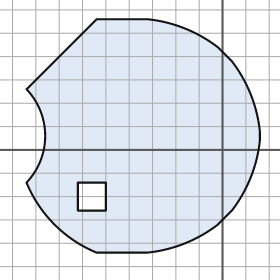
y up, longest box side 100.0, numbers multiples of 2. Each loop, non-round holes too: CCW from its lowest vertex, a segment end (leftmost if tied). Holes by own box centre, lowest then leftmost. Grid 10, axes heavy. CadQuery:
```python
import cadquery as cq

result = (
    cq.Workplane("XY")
    .moveTo(-54.0, -44.0)
    .lineTo(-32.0, -44.0)
    .threePointArc((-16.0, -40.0), (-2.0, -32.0))
    .lineTo(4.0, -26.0)
    .threePointArc((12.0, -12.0), (16.0, 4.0))
    .lineTo(16.0, 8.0)
    .threePointArc((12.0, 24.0), (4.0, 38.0))
    .lineTo(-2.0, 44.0)
    .threePointArc((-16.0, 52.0), (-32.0, 56.0))
    .lineTo(-54.0, 56.0)
    .lineTo(-84.0, 26.0)
    .threePointArc((-76.0, 6.0), (-84.0, -14.0))
    .threePointArc((-72.0, -32.0), (-54.0, -44.0))
    .close()
    .moveTo(-62.0, -26.0)
    .lineTo(-50.0, -26.0)
    .lineTo(-50.0, -14.0)
    .lineTo(-62.0, -14.0)
    .close()
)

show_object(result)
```